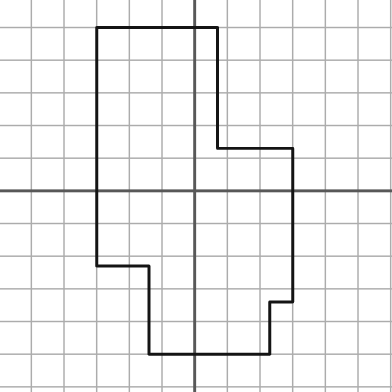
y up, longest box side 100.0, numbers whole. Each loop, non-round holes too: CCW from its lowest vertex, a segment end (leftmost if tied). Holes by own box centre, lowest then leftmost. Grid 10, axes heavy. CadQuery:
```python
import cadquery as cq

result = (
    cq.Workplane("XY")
    .moveTo(-14.0, -50.0)
    .lineTo(23.0, -50.0)
    .lineTo(23.0, -34.0)
    .lineTo(30.0, -34.0)
    .lineTo(30.0, 13.0)
    .lineTo(7.0, 13.0)
    .lineTo(7.0, 50.0)
    .lineTo(-30.0, 50.0)
    .lineTo(-30.0, -23.0)
    .lineTo(-14.0, -23.0)
    .close()
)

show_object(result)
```